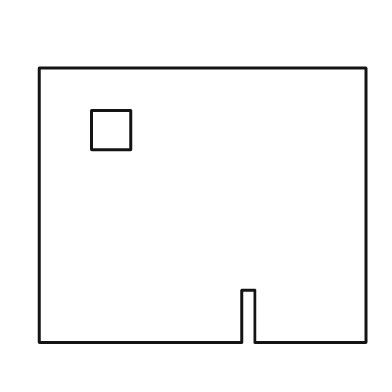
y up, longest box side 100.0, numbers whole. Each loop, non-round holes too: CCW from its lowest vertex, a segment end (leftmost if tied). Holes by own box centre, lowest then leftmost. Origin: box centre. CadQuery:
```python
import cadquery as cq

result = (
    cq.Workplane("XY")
    .moveTo(-50.0, -42.0)
    .lineTo(12.0, -42.0)
    .lineTo(12.0, -26.0)
    .lineTo(16.0, -26.0)
    .lineTo(16.0, -42.0)
    .lineTo(50.0, -42.0)
    .lineTo(50.0, 42.0)
    .lineTo(-50.0, 42.0)
    .close()
    .moveTo(-34.0, 17.0)
    .lineTo(-22.0, 17.0)
    .lineTo(-22.0, 29.0)
    .lineTo(-34.0, 29.0)
    .close()
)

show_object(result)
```